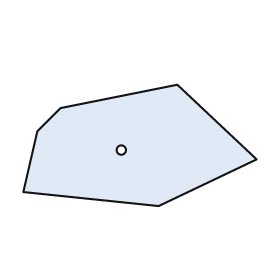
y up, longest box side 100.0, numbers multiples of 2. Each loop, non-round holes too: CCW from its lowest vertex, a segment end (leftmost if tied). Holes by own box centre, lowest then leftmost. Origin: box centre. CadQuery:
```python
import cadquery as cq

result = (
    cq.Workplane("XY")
    .moveTo(8.0, -26.0)
    .lineTo(50.0, -6.0)
    .lineTo(16.0, 26.0)
    .lineTo(-34.0, 16.0)
    .lineTo(-44.0, 6.0)
    .lineTo(-50.0, -20.0)
    .close()
    .moveTo(-8.0, -2.0)
    .circle(2.0)
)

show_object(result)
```